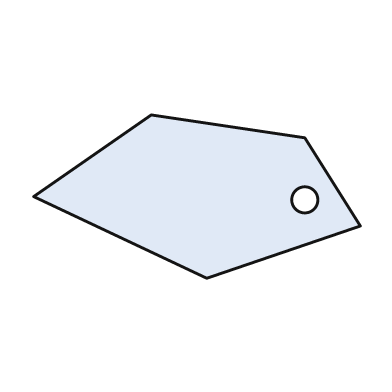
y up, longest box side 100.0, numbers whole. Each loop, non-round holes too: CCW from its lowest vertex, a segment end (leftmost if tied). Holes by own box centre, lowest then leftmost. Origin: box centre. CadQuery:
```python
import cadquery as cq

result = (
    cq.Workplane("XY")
    .moveTo(3.0, -25.0)
    .lineTo(50.0, -9.0)
    .lineTo(33.0, 18.0)
    .lineTo(-14.0, 25.0)
    .lineTo(-50.0, 0.0)
    .close()
    .moveTo(33.0, -1.0)
    .circle(4.0)
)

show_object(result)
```